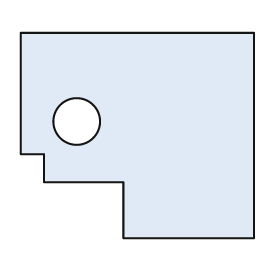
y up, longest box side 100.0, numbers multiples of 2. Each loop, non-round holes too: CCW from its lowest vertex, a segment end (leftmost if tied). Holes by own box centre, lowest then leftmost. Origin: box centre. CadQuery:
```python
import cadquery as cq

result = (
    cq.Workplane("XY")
    .moveTo(-6.0, -44.0)
    .lineTo(50.0, -44.0)
    .lineTo(50.0, 44.0)
    .lineTo(-50.0, 44.0)
    .lineTo(-50.0, -8.0)
    .lineTo(-40.0, -8.0)
    .lineTo(-40.0, -20.0)
    .lineTo(-6.0, -20.0)
    .close()
    .moveTo(-26.0, 6.0)
    .circle(10.0)
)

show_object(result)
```